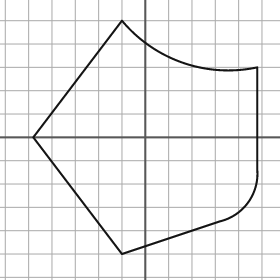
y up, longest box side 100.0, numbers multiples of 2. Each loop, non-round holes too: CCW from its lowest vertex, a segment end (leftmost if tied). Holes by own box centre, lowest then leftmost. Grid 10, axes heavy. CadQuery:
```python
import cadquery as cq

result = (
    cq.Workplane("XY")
    .moveTo(-10.0, -50.0)
    .lineTo(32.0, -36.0)
    .threePointArc((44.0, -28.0), (48.0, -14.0))
    .lineTo(48.0, 30.0)
    .threePointArc((16.0, 32.0), (-10.0, 50.0))
    .lineTo(-48.0, 0.0)
    .close()
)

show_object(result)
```